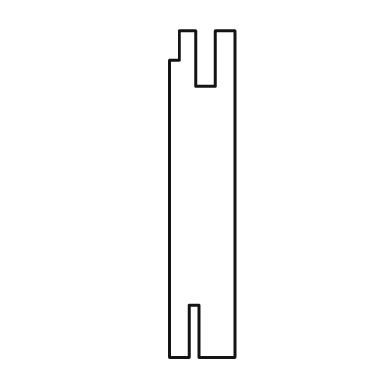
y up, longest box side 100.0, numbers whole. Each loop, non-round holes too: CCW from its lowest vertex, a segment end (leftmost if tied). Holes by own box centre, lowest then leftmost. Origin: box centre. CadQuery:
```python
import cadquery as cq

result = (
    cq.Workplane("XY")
    .moveTo(-10.0, -50.0)
    .lineTo(-4.0, -50.0)
    .lineTo(-4.0, -34.0)
    .lineTo(-1.0, -34.0)
    .lineTo(-1.0, -50.0)
    .lineTo(10.0, -50.0)
    .lineTo(10.0, 50.0)
    .lineTo(4.0, 50.0)
    .lineTo(4.0, 33.0)
    .lineTo(-2.0, 33.0)
    .lineTo(-2.0, 50.0)
    .lineTo(-7.0, 50.0)
    .lineTo(-7.0, 41.0)
    .lineTo(-10.0, 41.0)
    .close()
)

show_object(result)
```